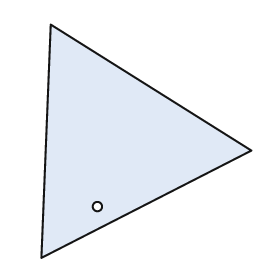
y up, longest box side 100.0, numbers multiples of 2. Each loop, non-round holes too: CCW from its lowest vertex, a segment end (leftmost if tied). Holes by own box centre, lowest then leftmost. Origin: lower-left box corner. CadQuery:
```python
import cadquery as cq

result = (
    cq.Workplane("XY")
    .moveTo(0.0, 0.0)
    .lineTo(90.0, 46.0)
    .lineTo(4.0, 100.0)
    .close()
    .moveTo(24.0, 22.0)
    .circle(2.0)
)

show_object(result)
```